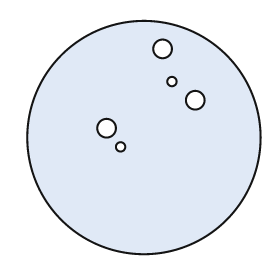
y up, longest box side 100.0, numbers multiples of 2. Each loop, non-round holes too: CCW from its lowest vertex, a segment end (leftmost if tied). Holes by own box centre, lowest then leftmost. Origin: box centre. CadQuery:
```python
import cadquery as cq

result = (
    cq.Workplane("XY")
    .moveTo(0.0, 0.0)
    .circle(50.0)
    .moveTo(-10.0, -4.0)
    .circle(2.0)
    .moveTo(-16.0, 4.0)
    .circle(4.0)
    .moveTo(22.0, 16.0)
    .circle(4.0)
    .moveTo(12.0, 24.0)
    .circle(2.0)
    .moveTo(8.0, 38.0)
    .circle(4.0)
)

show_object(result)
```